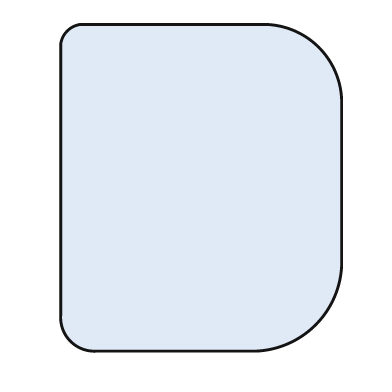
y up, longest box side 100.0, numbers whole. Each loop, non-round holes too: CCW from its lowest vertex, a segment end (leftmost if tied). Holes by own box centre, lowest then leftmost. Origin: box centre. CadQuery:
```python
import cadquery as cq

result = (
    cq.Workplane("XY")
    .moveTo(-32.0, -50.0)
    .lineTo(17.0, -50.0)
    .threePointArc((35.0, -42.0), (43.0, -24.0))
    .lineTo(43.0, 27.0)
    .threePointArc((36.0, 43.0), (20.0, 50.0))
    .lineTo(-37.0, 50.0)
    .threePointArc((-41.0, 48.0), (-43.0, 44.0))
    .lineTo(-43.0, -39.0)
    .threePointArc((-40.0, -47.0), (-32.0, -50.0))
    .close()
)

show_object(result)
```